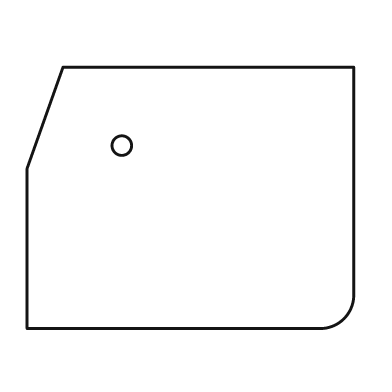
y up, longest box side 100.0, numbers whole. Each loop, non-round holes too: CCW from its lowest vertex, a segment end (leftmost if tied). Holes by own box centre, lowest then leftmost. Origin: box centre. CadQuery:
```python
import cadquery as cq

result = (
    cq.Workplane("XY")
    .moveTo(-50.0, -40.0)
    .lineTo(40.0, -40.0)
    .threePointArc((47.0, -37.0), (50.0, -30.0))
    .lineTo(50.0, 40.0)
    .lineTo(-39.0, 40.0)
    .lineTo(-50.0, 9.0)
    .close()
    .moveTo(-21.0, 16.0)
    .circle(3.0)
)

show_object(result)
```